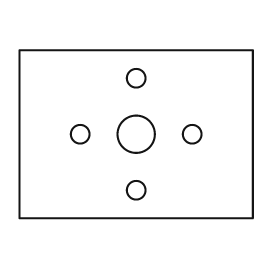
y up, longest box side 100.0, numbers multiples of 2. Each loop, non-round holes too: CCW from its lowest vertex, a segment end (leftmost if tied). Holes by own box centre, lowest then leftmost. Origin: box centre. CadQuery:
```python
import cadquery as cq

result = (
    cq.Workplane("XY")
    .moveTo(-50.0, -36.0)
    .lineTo(50.0, -36.0)
    .lineTo(50.0, 36.0)
    .lineTo(-50.0, 36.0)
    .close()
    .moveTo(0.0, -24.0)
    .circle(4.0)
    .moveTo(-24.0, 0.0)
    .circle(4.0)
    .moveTo(0.0, 0.0)
    .circle(8.0)
    .moveTo(24.0, 0.0)
    .circle(4.0)
    .moveTo(0.0, 24.0)
    .circle(4.0)
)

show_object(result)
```